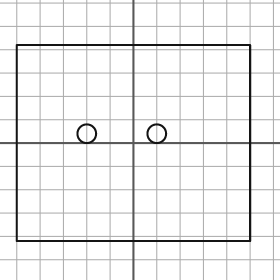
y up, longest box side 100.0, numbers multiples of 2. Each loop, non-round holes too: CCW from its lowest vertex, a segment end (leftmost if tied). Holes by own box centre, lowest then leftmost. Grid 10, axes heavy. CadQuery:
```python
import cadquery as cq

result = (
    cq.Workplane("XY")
    .moveTo(-50.0, -42.0)
    .lineTo(50.0, -42.0)
    .lineTo(50.0, 42.0)
    .lineTo(-50.0, 42.0)
    .close()
    .moveTo(-20.0, 4.0)
    .circle(4.0)
    .moveTo(10.0, 4.0)
    .circle(4.0)
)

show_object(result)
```